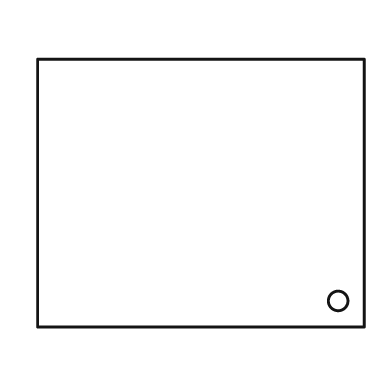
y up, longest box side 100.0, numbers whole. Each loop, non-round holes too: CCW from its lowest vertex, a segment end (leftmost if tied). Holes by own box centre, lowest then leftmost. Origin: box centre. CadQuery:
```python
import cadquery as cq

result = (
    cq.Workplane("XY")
    .moveTo(-50.0, -41.0)
    .lineTo(50.0, -41.0)
    .lineTo(50.0, 41.0)
    .lineTo(-50.0, 41.0)
    .close()
    .moveTo(42.0, -33.0)
    .circle(3.0)
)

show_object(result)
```